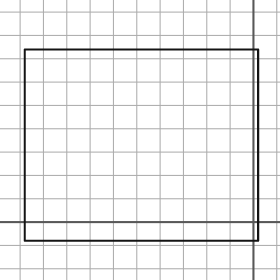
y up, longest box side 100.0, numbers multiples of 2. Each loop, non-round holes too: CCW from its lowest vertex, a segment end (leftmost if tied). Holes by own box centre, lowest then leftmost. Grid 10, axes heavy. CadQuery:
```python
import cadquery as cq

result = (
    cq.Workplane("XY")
    .moveTo(-98.0, -8.0)
    .lineTo(2.0, -8.0)
    .lineTo(2.0, 74.0)
    .lineTo(-98.0, 74.0)
    .close()
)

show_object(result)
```